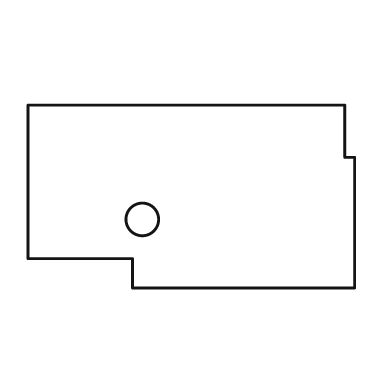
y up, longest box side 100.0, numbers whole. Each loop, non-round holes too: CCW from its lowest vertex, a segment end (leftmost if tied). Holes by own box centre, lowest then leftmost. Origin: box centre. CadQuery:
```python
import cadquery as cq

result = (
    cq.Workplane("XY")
    .moveTo(-18.0, -28.0)
    .lineTo(50.0, -28.0)
    .lineTo(50.0, 12.0)
    .lineTo(47.0, 12.0)
    .lineTo(47.0, 28.0)
    .lineTo(-50.0, 28.0)
    .lineTo(-50.0, -19.0)
    .lineTo(-18.0, -19.0)
    .close()
    .moveTo(-15.0, -7.0)
    .circle(5.0)
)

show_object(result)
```